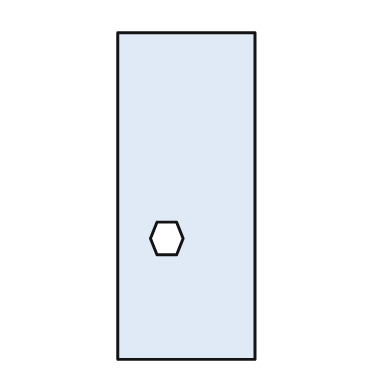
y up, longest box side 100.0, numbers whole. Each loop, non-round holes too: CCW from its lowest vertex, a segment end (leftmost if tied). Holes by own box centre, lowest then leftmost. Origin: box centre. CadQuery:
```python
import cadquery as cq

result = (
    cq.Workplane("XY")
    .moveTo(-21.0, -50.0)
    .lineTo(21.0, -50.0)
    .lineTo(21.0, 50.0)
    .lineTo(-21.0, 50.0)
    .close()
    .moveTo(-9.0, -18.0)
    .lineTo(-3.0, -18.0)
    .lineTo(-1.0, -13.0)
    .lineTo(-3.0, -8.0)
    .lineTo(-9.0, -8.0)
    .lineTo(-11.0, -13.0)
    .close()
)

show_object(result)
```